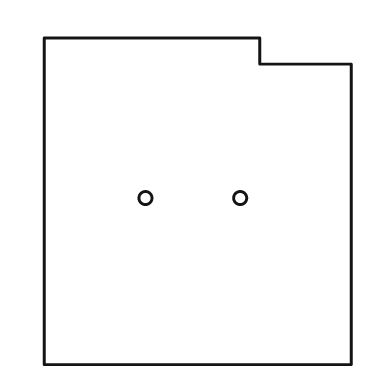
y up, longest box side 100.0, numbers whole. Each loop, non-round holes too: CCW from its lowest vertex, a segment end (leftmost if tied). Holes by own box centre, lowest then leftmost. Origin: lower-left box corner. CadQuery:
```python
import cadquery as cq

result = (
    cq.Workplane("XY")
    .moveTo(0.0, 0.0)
    .lineTo(94.0, 0.0)
    .lineTo(94.0, 92.0)
    .lineTo(66.0, 92.0)
    .lineTo(66.0, 100.0)
    .lineTo(0.0, 100.0)
    .close()
    .moveTo(31.0, 51.0)
    .circle(2.0)
    .moveTo(60.0, 51.0)
    .circle(2.0)
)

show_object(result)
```